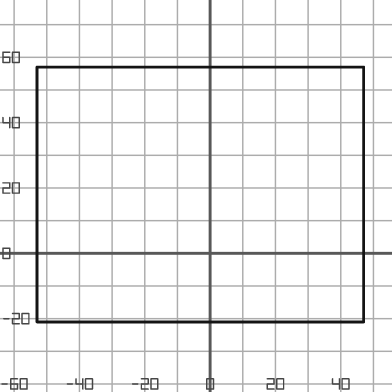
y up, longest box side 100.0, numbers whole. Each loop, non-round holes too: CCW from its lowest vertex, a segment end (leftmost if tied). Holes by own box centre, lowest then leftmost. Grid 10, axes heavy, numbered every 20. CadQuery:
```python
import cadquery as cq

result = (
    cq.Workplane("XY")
    .moveTo(-53.0, -21.0)
    .lineTo(47.0, -21.0)
    .lineTo(47.0, 57.0)
    .lineTo(-53.0, 57.0)
    .close()
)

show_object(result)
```